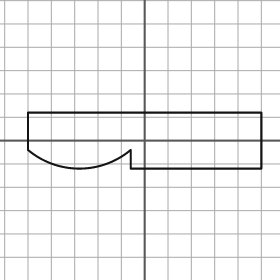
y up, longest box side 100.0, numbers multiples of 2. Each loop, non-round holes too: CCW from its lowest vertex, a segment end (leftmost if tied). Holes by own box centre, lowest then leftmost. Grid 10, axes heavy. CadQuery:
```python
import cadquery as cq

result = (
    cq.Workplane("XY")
    .moveTo(-6.0, -12.0)
    .lineTo(50.0, -12.0)
    .lineTo(50.0, 12.0)
    .lineTo(-50.0, 12.0)
    .lineTo(-50.0, -4.0)
    .threePointArc((-28.0, -12.0), (-6.0, -4.0))
    .close()
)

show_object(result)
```